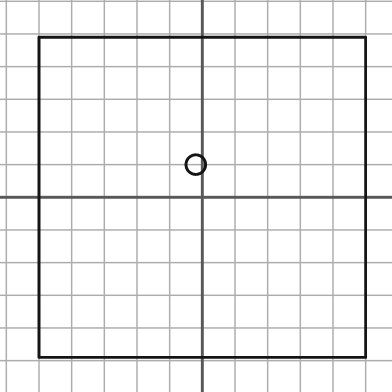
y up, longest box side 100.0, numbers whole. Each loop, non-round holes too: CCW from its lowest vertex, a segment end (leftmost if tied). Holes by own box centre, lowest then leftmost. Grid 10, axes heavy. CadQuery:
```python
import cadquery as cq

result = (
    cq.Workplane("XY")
    .moveTo(-50.0, -49.0)
    .lineTo(50.0, -49.0)
    .lineTo(50.0, 49.0)
    .lineTo(-50.0, 49.0)
    .close()
    .moveTo(-2.0, 10.0)
    .circle(3.0)
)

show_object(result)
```